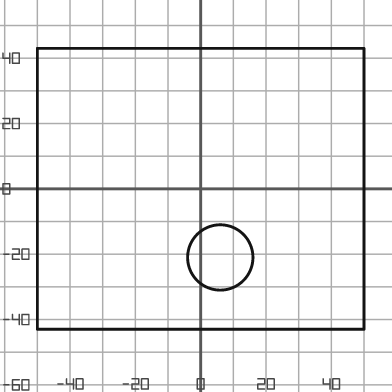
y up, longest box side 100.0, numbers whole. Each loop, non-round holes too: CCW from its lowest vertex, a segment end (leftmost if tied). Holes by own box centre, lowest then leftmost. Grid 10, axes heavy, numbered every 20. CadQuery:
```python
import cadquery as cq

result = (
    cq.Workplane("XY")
    .moveTo(-50.0, -43.0)
    .lineTo(50.0, -43.0)
    .lineTo(50.0, 43.0)
    .lineTo(-50.0, 43.0)
    .close()
    .moveTo(6.0, -21.0)
    .circle(10.0)
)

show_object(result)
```